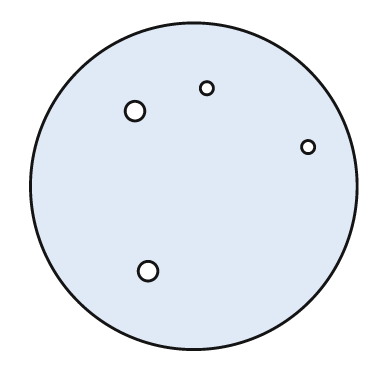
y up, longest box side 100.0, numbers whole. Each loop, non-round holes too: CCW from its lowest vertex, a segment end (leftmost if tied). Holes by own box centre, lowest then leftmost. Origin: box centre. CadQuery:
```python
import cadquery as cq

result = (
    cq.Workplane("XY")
    .moveTo(0.0, 0.0)
    .circle(50.0)
    .moveTo(-14.0, -26.0)
    .circle(3.0)
    .moveTo(35.0, 12.0)
    .circle(2.0)
    .moveTo(-18.0, 23.0)
    .circle(3.0)
    .moveTo(4.0, 30.0)
    .circle(2.0)
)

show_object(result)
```